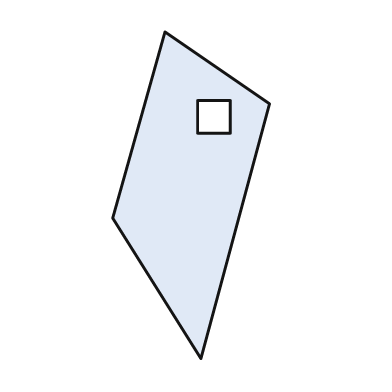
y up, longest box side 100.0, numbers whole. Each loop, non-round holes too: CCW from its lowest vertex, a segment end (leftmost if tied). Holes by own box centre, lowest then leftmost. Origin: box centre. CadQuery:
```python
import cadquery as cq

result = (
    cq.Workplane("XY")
    .moveTo(3.0, -50.0)
    .lineTo(24.0, 28.0)
    .lineTo(-8.0, 50.0)
    .lineTo(-24.0, -7.0)
    .close()
    .moveTo(2.0, 19.0)
    .lineTo(12.0, 19.0)
    .lineTo(12.0, 29.0)
    .lineTo(2.0, 29.0)
    .close()
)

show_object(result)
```